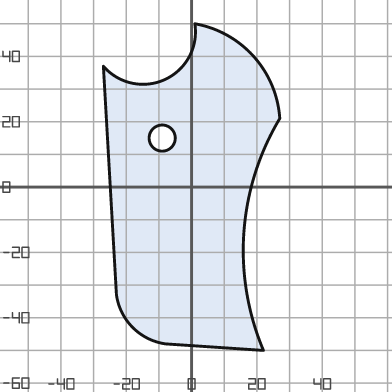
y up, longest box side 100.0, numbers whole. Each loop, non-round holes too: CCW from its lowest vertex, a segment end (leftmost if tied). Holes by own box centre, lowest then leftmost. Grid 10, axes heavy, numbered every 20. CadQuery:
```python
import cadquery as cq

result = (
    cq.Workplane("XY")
    .moveTo(22.0, -50.0)
    .threePointArc((16.0, -14.0), (27.0, 21.0))
    .threePointArc((19.0, 40.0), (1.0, 50.0))
    .threePointArc((-8.0, 33.0), (-27.0, 37.0))
    .lineTo(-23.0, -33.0)
    .threePointArc((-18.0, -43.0), (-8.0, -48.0))
    .close()
    .moveTo(-9.0, 15.0)
    .circle(4.0)
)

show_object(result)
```